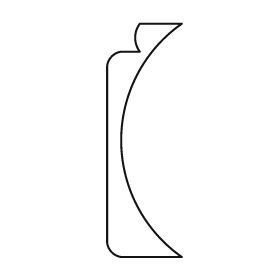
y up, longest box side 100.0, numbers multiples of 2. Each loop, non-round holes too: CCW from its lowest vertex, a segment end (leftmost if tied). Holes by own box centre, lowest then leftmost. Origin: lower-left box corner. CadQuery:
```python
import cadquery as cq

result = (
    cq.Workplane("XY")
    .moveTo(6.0, 0.0)
    .lineTo(32.0, 0.0)
    .threePointArc((6.0, 50.0), (32.0, 100.0))
    .lineTo(14.0, 100.0)
    .threePointArc((12.0, 94.0), (14.0, 88.0))
    .lineTo(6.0, 88.0)
    .threePointArc((2.0, 86.0), (0.0, 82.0))
    .lineTo(0.0, 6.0)
    .threePointArc((2.0, 2.0), (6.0, 0.0))
    .close()
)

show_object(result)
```